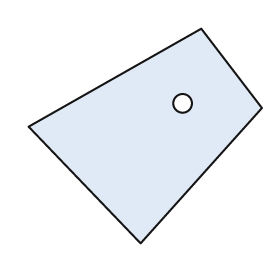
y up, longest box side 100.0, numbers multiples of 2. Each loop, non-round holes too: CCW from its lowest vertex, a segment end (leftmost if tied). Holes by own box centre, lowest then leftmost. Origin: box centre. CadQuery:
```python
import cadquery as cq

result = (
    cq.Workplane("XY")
    .moveTo(-2.0, -46.0)
    .lineTo(50.0, 12.0)
    .lineTo(24.0, 46.0)
    .lineTo(-50.0, 4.0)
    .close()
    .moveTo(16.0, 14.0)
    .circle(4.0)
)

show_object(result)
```